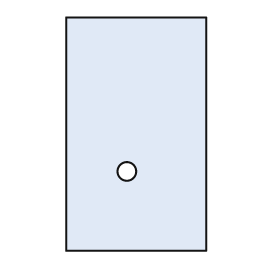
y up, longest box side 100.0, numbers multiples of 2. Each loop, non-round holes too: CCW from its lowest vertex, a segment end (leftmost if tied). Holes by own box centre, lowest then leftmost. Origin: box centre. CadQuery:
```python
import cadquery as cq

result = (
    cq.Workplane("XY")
    .moveTo(-30.0, -50.0)
    .lineTo(30.0, -50.0)
    .lineTo(30.0, 50.0)
    .lineTo(-30.0, 50.0)
    .close()
    .moveTo(-4.0, -16.0)
    .circle(4.0)
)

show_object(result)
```